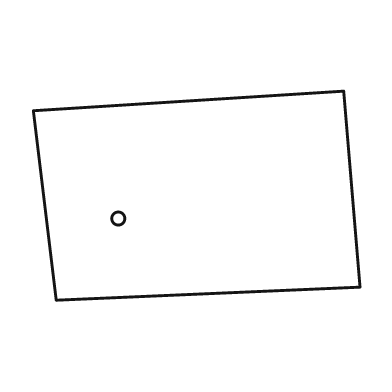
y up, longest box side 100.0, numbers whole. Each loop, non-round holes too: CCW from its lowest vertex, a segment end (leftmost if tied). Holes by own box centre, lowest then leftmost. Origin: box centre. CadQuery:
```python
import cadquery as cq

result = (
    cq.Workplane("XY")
    .moveTo(-43.0, -32.0)
    .lineTo(50.0, -28.0)
    .lineTo(45.0, 32.0)
    .lineTo(-50.0, 26.0)
    .close()
    .moveTo(-24.0, -7.0)
    .circle(2.0)
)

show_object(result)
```